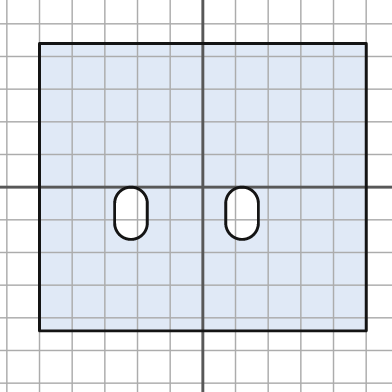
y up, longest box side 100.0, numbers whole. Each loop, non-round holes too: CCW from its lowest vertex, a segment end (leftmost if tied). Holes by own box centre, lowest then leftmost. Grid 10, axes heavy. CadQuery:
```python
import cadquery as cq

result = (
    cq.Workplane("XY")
    .moveTo(-50.0, -44.0)
    .lineTo(50.0, -44.0)
    .lineTo(50.0, 44.0)
    .lineTo(-50.0, 44.0)
    .close()
    .moveTo(-27.0, -11.0)
    .threePointArc((-22.0, -16.0), (-17.0, -11.0))
    .lineTo(-17.0, -5.0)
    .threePointArc((-22.0, 0.0), (-27.0, -5.0))
    .close()
    .moveTo(7.0, -11.0)
    .threePointArc((12.0, -16.0), (17.0, -11.0))
    .lineTo(17.0, -5.0)
    .threePointArc((12.0, 0.0), (7.0, -5.0))
    .close()
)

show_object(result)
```